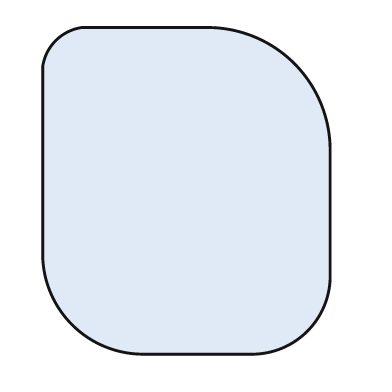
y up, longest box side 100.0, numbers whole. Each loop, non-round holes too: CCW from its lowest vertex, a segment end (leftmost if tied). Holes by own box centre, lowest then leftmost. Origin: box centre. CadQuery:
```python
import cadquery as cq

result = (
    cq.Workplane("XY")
    .moveTo(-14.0, -50.0)
    .lineTo(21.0, -50.0)
    .threePointArc((37.0, -43.0), (44.0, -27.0))
    .lineTo(44.0, 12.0)
    .threePointArc((33.0, 39.0), (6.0, 50.0))
    .lineTo(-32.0, 50.0)
    .threePointArc((-40.0, 46.0), (-44.0, 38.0))
    .lineTo(-44.0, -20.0)
    .threePointArc((-35.0, -41.0), (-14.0, -50.0))
    .close()
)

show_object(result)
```